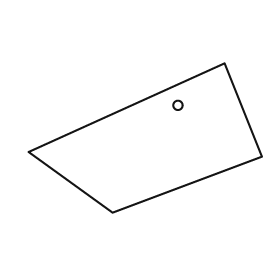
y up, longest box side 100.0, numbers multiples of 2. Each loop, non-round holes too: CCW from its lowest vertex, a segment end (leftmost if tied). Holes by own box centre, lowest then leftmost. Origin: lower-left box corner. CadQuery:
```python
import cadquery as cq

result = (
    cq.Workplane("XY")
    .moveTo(36.0, 0.0)
    .lineTo(100.0, 24.0)
    .lineTo(84.0, 64.0)
    .lineTo(0.0, 26.0)
    .close()
    .moveTo(64.0, 46.0)
    .circle(2.0)
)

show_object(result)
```